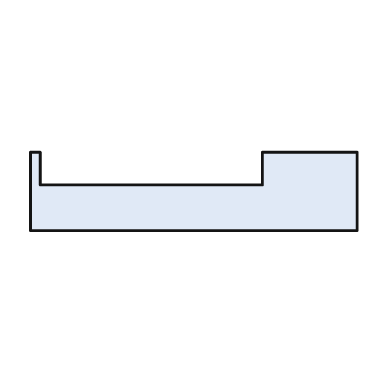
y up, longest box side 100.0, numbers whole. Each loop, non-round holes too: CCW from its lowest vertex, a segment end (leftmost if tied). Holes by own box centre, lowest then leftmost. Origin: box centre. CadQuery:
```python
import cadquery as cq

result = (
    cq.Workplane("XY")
    .moveTo(-50.0, -12.0)
    .lineTo(50.0, -12.0)
    .lineTo(50.0, 12.0)
    .lineTo(21.0, 12.0)
    .lineTo(21.0, 2.0)
    .lineTo(-47.0, 2.0)
    .lineTo(-47.0, 12.0)
    .lineTo(-50.0, 12.0)
    .close()
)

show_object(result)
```